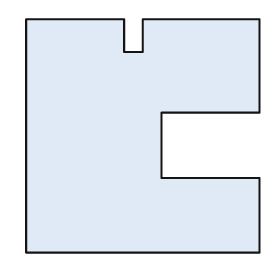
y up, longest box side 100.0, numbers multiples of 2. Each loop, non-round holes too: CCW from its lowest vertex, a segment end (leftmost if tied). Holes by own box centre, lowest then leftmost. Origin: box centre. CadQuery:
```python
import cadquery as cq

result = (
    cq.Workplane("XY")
    .moveTo(-50.0, -50.0)
    .lineTo(50.0, -50.0)
    .lineTo(50.0, -18.0)
    .lineTo(8.0, -18.0)
    .lineTo(8.0, 10.0)
    .lineTo(50.0, 10.0)
    .lineTo(50.0, 50.0)
    .lineTo(0.0, 50.0)
    .lineTo(0.0, 36.0)
    .lineTo(-8.0, 36.0)
    .lineTo(-8.0, 50.0)
    .lineTo(-50.0, 50.0)
    .close()
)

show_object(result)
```